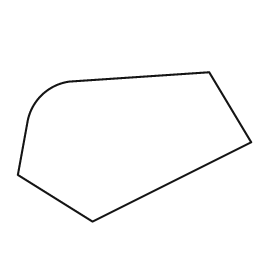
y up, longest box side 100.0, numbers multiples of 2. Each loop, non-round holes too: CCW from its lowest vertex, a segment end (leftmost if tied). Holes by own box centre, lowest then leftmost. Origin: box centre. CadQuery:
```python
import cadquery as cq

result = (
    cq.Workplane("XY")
    .moveTo(-18.0, -32.0)
    .lineTo(50.0, 2.0)
    .lineTo(32.0, 32.0)
    .lineTo(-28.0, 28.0)
    .threePointArc((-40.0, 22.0), (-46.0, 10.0))
    .lineTo(-50.0, -12.0)
    .close()
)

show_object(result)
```